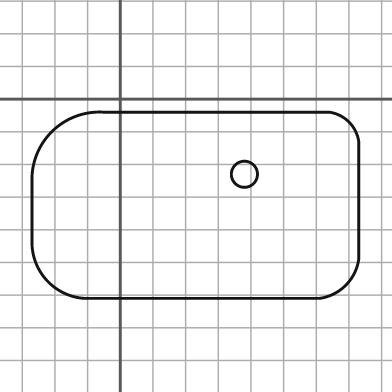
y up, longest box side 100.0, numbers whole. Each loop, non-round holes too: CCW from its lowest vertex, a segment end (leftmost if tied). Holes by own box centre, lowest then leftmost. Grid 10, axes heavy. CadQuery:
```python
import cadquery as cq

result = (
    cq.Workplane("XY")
    .moveTo(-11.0, -61.0)
    .lineTo(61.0, -61.0)
    .threePointArc((69.0, -57.0), (73.0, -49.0))
    .lineTo(73.0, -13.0)
    .threePointArc((70.0, -7.0), (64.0, -4.0))
    .lineTo(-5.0, -4.0)
    .threePointArc((-21.0, -10.0), (-27.0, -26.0))
    .lineTo(-27.0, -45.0)
    .threePointArc((-22.0, -56.0), (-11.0, -61.0))
    .close()
    .moveTo(38.0, -23.0)
    .circle(4.0)
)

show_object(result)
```